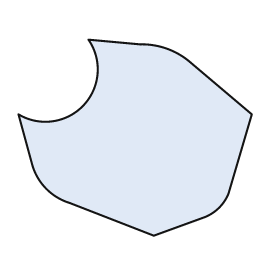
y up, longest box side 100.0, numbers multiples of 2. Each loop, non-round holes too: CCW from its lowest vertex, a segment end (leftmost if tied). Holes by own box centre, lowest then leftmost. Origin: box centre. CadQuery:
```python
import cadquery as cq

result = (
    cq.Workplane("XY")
    .moveTo(8.0, -42.0)
    .lineTo(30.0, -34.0)
    .threePointArc((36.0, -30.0), (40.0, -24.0))
    .lineTo(50.0, 10.0)
    .lineTo(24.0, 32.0)
    .threePointArc((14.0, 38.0), (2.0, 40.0))
    .lineTo(-20.0, 42.0)
    .threePointArc((-22.0, 14.0), (-50.0, 10.0))
    .lineTo(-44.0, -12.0)
    .threePointArc((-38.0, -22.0), (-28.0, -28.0))
    .close()
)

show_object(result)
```